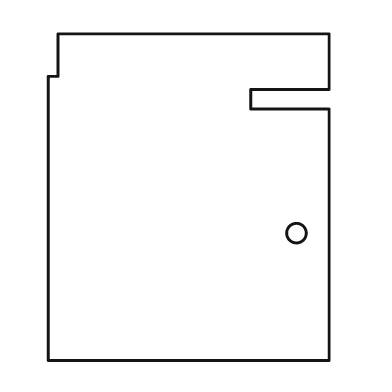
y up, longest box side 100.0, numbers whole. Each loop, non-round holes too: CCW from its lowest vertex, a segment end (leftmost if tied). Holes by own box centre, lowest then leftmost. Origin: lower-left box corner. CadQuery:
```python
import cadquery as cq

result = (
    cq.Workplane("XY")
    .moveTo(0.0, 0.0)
    .lineTo(86.0, 0.0)
    .lineTo(86.0, 77.0)
    .lineTo(62.0, 77.0)
    .lineTo(62.0, 83.0)
    .lineTo(86.0, 83.0)
    .lineTo(86.0, 100.0)
    .lineTo(3.0, 100.0)
    .lineTo(3.0, 87.0)
    .lineTo(0.0, 87.0)
    .close()
    .moveTo(76.0, 39.0)
    .circle(3.0)
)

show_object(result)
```